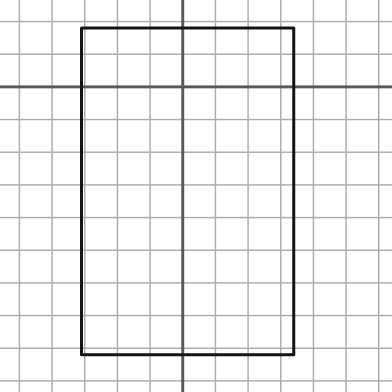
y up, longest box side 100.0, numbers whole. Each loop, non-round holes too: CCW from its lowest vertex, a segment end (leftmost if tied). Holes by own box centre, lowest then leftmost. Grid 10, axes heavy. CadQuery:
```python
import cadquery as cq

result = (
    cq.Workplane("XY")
    .moveTo(-31.0, -82.0)
    .lineTo(34.0, -82.0)
    .lineTo(34.0, 18.0)
    .lineTo(-31.0, 18.0)
    .close()
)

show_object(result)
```